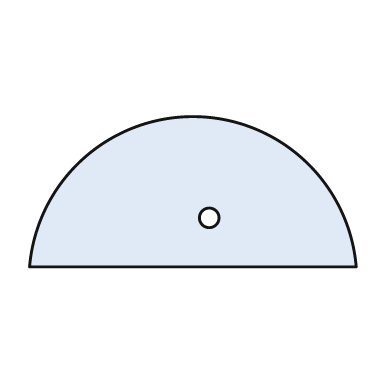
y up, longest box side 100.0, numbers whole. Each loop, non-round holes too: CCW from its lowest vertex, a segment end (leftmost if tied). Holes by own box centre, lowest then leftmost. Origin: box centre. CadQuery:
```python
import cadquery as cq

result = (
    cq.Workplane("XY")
    .moveTo(-50.0, -23.0)
    .lineTo(50.0, -23.0)
    .threePointArc((0.0, 23.0), (-50.0, -23.0))
    .close()
    .moveTo(5.0, -8.0)
    .circle(3.0)
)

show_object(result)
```